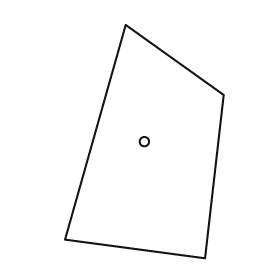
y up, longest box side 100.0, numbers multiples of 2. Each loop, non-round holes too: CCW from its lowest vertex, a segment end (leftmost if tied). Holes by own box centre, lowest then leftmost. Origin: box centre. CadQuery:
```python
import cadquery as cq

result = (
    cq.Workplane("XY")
    .moveTo(26.0, -50.0)
    .lineTo(34.0, 20.0)
    .lineTo(-8.0, 50.0)
    .lineTo(-34.0, -42.0)
    .close()
    .moveTo(0.0, 0.0)
    .circle(2.0)
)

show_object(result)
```